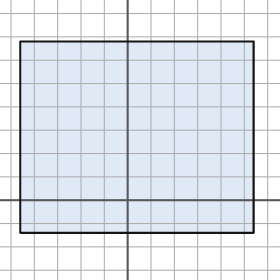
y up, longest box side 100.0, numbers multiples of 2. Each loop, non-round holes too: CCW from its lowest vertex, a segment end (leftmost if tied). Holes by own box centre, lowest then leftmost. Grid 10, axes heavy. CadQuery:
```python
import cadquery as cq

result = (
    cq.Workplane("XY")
    .moveTo(-46.0, -14.0)
    .lineTo(54.0, -14.0)
    .lineTo(54.0, 68.0)
    .lineTo(-46.0, 68.0)
    .close()
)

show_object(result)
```